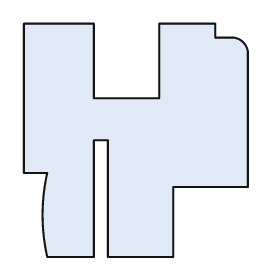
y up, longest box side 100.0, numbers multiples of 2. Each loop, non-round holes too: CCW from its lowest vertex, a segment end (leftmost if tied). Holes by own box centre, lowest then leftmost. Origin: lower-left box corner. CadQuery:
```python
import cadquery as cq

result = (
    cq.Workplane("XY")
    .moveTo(10.0, 0.0)
    .lineTo(30.0, 0.0)
    .lineTo(30.0, 50.0)
    .lineTo(36.0, 50.0)
    .lineTo(36.0, 0.0)
    .lineTo(64.0, 0.0)
    .lineTo(64.0, 30.0)
    .lineTo(96.0, 30.0)
    .lineTo(96.0, 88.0)
    .threePointArc((94.0, 92.0), (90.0, 94.0))
    .lineTo(82.0, 94.0)
    .lineTo(82.0, 100.0)
    .lineTo(58.0, 100.0)
    .lineTo(58.0, 68.0)
    .lineTo(30.0, 68.0)
    .lineTo(30.0, 100.0)
    .lineTo(0.0, 100.0)
    .lineTo(0.0, 36.0)
    .lineTo(10.0, 36.0)
    .threePointArc((8.0, 18.0), (10.0, 0.0))
    .close()
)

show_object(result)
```